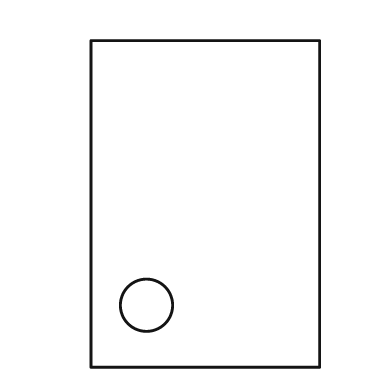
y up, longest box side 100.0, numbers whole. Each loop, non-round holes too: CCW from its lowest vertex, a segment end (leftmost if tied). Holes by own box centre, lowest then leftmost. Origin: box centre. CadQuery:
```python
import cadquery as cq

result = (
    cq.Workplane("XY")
    .moveTo(-35.0, -50.0)
    .lineTo(35.0, -50.0)
    .lineTo(35.0, 50.0)
    .lineTo(-35.0, 50.0)
    .close()
    .moveTo(-18.0, -31.0)
    .circle(8.0)
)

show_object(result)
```